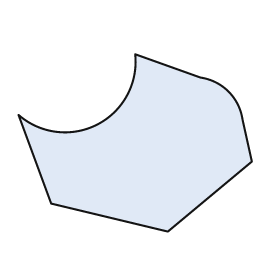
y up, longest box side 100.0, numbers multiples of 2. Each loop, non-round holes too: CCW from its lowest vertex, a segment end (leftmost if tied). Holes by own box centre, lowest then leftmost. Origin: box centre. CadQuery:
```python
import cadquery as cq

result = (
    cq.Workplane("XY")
    .moveTo(14.0, -38.0)
    .lineTo(50.0, -8.0)
    .lineTo(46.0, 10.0)
    .threePointArc((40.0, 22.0), (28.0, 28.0))
    .lineTo(0.0, 38.0)
    .threePointArc((-16.0, 8.0), (-50.0, 12.0))
    .lineTo(-36.0, -26.0)
    .close()
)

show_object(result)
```